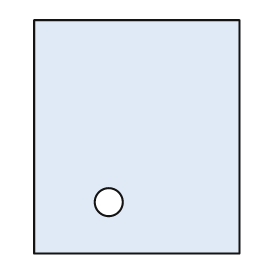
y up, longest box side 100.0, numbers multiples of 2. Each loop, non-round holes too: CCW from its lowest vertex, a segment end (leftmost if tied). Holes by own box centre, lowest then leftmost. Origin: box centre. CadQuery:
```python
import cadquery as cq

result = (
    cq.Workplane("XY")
    .moveTo(-44.0, -50.0)
    .lineTo(44.0, -50.0)
    .lineTo(44.0, 50.0)
    .lineTo(-44.0, 50.0)
    .close()
    .moveTo(-12.0, -28.0)
    .circle(6.0)
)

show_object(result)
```